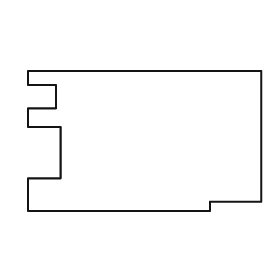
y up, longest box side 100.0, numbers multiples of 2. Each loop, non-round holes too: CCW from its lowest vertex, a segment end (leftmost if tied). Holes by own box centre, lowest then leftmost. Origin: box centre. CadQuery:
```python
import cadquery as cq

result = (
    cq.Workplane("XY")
    .moveTo(-50.0, -30.0)
    .lineTo(28.0, -30.0)
    .lineTo(28.0, -26.0)
    .lineTo(50.0, -26.0)
    .lineTo(50.0, 30.0)
    .lineTo(-50.0, 30.0)
    .lineTo(-50.0, 24.0)
    .lineTo(-38.0, 24.0)
    .lineTo(-38.0, 14.0)
    .lineTo(-50.0, 14.0)
    .lineTo(-50.0, 6.0)
    .lineTo(-36.0, 6.0)
    .lineTo(-36.0, -16.0)
    .lineTo(-50.0, -16.0)
    .close()
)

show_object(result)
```